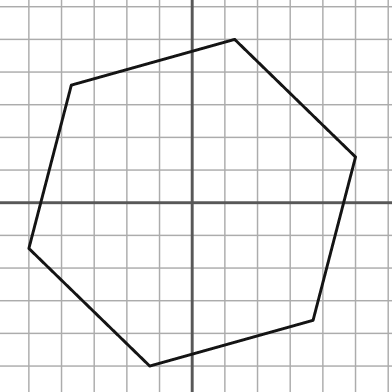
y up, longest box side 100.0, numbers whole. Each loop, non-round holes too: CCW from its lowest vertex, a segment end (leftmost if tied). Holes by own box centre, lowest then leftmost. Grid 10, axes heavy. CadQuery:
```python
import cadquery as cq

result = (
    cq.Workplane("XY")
    .moveTo(-13.0, -50.0)
    .lineTo(37.0, -36.0)
    .lineTo(50.0, 14.0)
    .lineTo(13.0, 50.0)
    .lineTo(-37.0, 36.0)
    .lineTo(-50.0, -14.0)
    .close()
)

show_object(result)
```